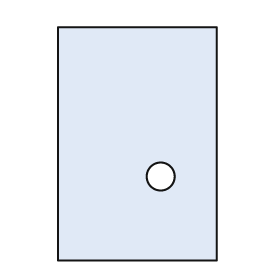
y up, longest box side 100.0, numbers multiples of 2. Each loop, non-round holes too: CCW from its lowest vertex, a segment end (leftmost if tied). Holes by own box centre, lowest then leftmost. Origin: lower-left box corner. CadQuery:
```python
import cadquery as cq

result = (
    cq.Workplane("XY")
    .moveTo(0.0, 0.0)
    .lineTo(68.0, 0.0)
    .lineTo(68.0, 100.0)
    .lineTo(0.0, 100.0)
    .close()
    .moveTo(44.0, 36.0)
    .circle(6.0)
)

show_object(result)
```